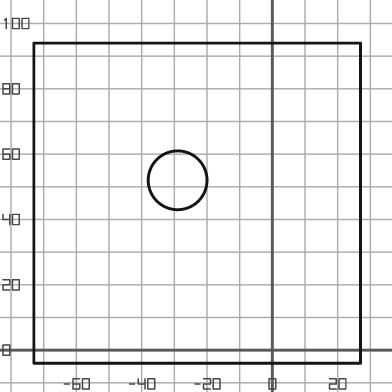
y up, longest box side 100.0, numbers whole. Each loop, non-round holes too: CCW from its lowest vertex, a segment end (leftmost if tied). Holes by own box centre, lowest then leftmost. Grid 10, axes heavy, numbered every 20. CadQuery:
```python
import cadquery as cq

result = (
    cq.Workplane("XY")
    .moveTo(-73.0, -4.0)
    .lineTo(27.0, -4.0)
    .lineTo(27.0, 94.0)
    .lineTo(-73.0, 94.0)
    .close()
    .moveTo(-29.0, 52.0)
    .circle(9.0)
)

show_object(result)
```